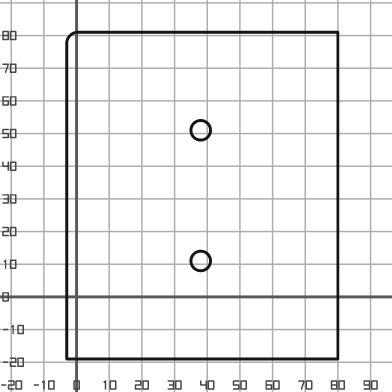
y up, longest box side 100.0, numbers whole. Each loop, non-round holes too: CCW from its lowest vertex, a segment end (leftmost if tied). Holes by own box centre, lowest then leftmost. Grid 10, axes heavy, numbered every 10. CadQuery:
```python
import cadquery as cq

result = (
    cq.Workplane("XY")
    .moveTo(-3.0, -19.0)
    .lineTo(80.0, -19.0)
    .lineTo(80.0, 81.0)
    .lineTo(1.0, 81.0)
    .threePointArc((-2.0, 80.0), (-3.0, 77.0))
    .close()
    .moveTo(38.0, 11.0)
    .circle(3.0)
    .moveTo(38.0, 51.0)
    .circle(3.0)
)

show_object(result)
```